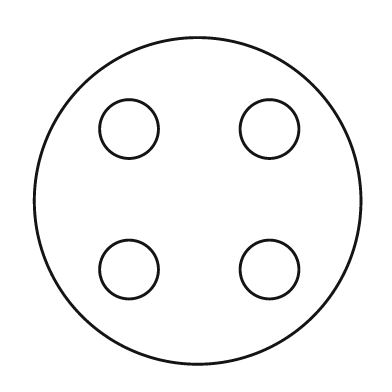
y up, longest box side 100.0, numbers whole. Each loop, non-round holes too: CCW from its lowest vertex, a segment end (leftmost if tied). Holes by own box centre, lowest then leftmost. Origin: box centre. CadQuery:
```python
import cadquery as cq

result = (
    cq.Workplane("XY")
    .moveTo(0.0, 0.0)
    .circle(50.0)
    .moveTo(-21.0, -21.0)
    .circle(9.0)
    .moveTo(22.0, -21.0)
    .circle(9.0)
    .moveTo(-21.0, 22.0)
    .circle(9.0)
    .moveTo(22.0, 22.0)
    .circle(9.0)
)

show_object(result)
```